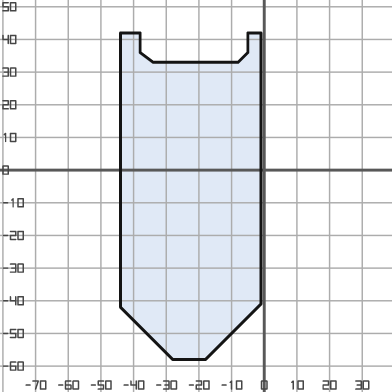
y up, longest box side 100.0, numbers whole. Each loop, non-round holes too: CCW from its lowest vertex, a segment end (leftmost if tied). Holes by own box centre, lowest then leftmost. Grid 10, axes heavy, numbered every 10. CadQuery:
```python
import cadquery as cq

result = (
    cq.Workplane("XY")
    .moveTo(-28.0, -58.0)
    .lineTo(-18.0, -58.0)
    .lineTo(-1.0, -41.0)
    .lineTo(-1.0, 42.0)
    .lineTo(-5.0, 42.0)
    .lineTo(-5.0, 36.0)
    .lineTo(-8.0, 33.0)
    .lineTo(-34.0, 33.0)
    .lineTo(-38.0, 36.0)
    .lineTo(-38.0, 42.0)
    .lineTo(-44.0, 42.0)
    .lineTo(-44.0, -42.0)
    .close()
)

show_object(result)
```